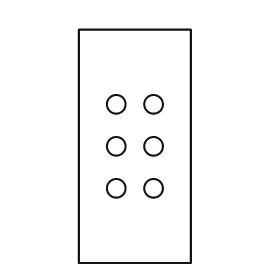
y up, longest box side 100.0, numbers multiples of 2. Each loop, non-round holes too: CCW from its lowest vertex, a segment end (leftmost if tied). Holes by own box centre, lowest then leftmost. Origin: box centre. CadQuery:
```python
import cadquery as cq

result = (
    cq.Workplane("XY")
    .moveTo(-24.0, -50.0)
    .lineTo(24.0, -50.0)
    .lineTo(24.0, 50.0)
    .lineTo(-24.0, 50.0)
    .close()
    .moveTo(-8.0, -18.0)
    .circle(4.0)
    .moveTo(8.0, -18.0)
    .circle(4.0)
    .moveTo(-8.0, 0.0)
    .circle(4.0)
    .moveTo(8.0, 0.0)
    .circle(4.0)
    .moveTo(-8.0, 18.0)
    .circle(4.0)
    .moveTo(8.0, 18.0)
    .circle(4.0)
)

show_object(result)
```